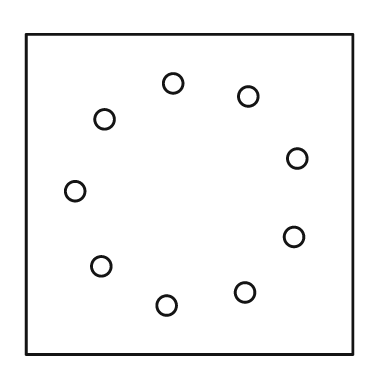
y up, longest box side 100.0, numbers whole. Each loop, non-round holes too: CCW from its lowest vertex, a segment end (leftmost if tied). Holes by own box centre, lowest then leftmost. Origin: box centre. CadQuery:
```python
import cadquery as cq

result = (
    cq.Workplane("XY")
    .moveTo(-50.0, -49.0)
    .lineTo(50.0, -49.0)
    .lineTo(50.0, 49.0)
    .lineTo(-50.0, 49.0)
    .close()
    .moveTo(-7.0, -34.0)
    .circle(3.0)
    .moveTo(17.0, -30.0)
    .circle(3.0)
    .moveTo(-27.0, -22.0)
    .circle(3.0)
    .moveTo(32.0, -13.0)
    .circle(3.0)
    .moveTo(-35.0, 1.0)
    .circle(3.0)
    .moveTo(33.0, 11.0)
    .circle(3.0)
    .moveTo(-26.0, 23.0)
    .circle(3.0)
    .moveTo(18.0, 30.0)
    .circle(3.0)
    .moveTo(-5.0, 34.0)
    .circle(3.0)
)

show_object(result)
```